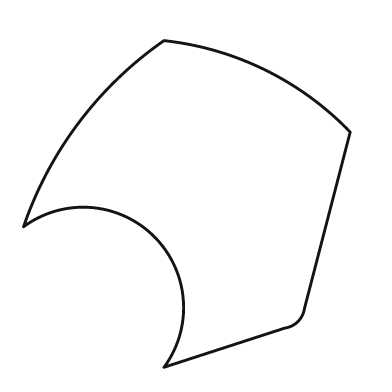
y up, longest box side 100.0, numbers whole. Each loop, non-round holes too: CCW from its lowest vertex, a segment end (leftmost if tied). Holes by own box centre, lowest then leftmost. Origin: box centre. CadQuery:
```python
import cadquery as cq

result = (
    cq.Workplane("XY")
    .moveTo(-7.0, -50.0)
    .lineTo(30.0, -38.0)
    .threePointArc((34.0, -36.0), (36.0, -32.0))
    .lineTo(50.0, 22.0)
    .threePointArc((24.0, 41.0), (-7.0, 50.0))
    .threePointArc((-33.0, 25.0), (-50.0, -7.0))
    .threePointArc((-10.0, -10.0), (-7.0, -50.0))
    .close()
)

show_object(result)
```